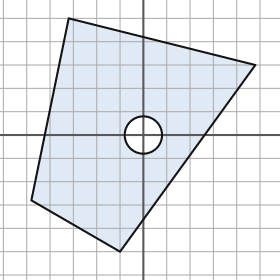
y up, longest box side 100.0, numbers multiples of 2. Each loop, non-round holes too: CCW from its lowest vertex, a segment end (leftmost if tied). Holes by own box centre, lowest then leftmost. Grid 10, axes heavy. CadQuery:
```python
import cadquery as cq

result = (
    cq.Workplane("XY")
    .moveTo(-10.0, -50.0)
    .lineTo(48.0, 30.0)
    .lineTo(-32.0, 50.0)
    .lineTo(-48.0, -28.0)
    .close()
    .moveTo(0.0, 0.0)
    .circle(8.0)
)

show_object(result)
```